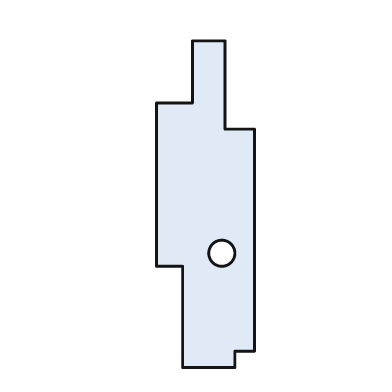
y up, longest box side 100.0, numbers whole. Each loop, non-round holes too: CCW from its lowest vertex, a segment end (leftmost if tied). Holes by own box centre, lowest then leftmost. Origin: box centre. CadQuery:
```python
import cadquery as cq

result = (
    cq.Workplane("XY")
    .moveTo(-7.0, -50.0)
    .lineTo(9.0, -50.0)
    .lineTo(9.0, -45.0)
    .lineTo(15.0, -45.0)
    .lineTo(15.0, 23.0)
    .lineTo(6.0, 23.0)
    .lineTo(6.0, 50.0)
    .lineTo(-4.0, 50.0)
    .lineTo(-4.0, 31.0)
    .lineTo(-15.0, 31.0)
    .lineTo(-15.0, -19.0)
    .lineTo(-7.0, -19.0)
    .close()
    .moveTo(5.0, -15.0)
    .circle(4.0)
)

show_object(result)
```